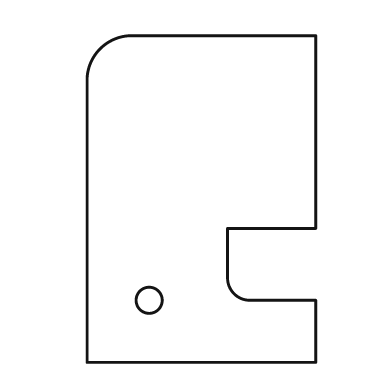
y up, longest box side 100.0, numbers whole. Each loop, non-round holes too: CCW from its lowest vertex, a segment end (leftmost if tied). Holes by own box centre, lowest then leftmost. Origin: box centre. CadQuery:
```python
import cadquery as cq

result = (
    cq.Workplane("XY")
    .moveTo(-35.0, -50.0)
    .lineTo(35.0, -50.0)
    .lineTo(35.0, -31.0)
    .lineTo(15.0, -31.0)
    .threePointArc((10.0, -29.0), (8.0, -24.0))
    .lineTo(8.0, -9.0)
    .lineTo(35.0, -9.0)
    .lineTo(35.0, 50.0)
    .lineTo(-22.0, 50.0)
    .threePointArc((-31.0, 46.0), (-35.0, 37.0))
    .close()
    .moveTo(-16.0, -31.0)
    .circle(4.0)
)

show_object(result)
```